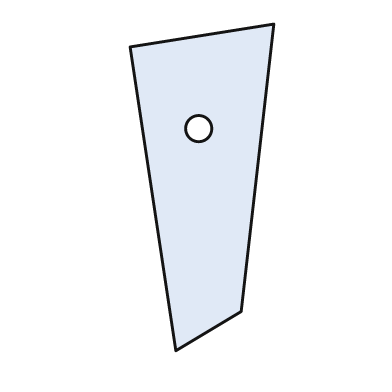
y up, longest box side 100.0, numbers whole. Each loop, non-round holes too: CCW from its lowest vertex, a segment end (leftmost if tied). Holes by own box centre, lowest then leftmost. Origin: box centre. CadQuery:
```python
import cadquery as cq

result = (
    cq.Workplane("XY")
    .moveTo(-8.0, -50.0)
    .lineTo(12.0, -38.0)
    .lineTo(22.0, 50.0)
    .lineTo(-22.0, 43.0)
    .close()
    .moveTo(-1.0, 18.0)
    .circle(4.0)
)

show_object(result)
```